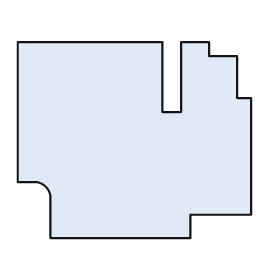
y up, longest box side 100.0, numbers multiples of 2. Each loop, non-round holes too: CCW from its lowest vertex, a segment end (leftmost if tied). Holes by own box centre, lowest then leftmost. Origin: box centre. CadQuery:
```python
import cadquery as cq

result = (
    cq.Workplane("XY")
    .moveTo(-36.0, -42.0)
    .lineTo(24.0, -42.0)
    .lineTo(24.0, -32.0)
    .lineTo(50.0, -32.0)
    .lineTo(50.0, 18.0)
    .lineTo(44.0, 18.0)
    .lineTo(44.0, 36.0)
    .lineTo(32.0, 36.0)
    .lineTo(32.0, 42.0)
    .lineTo(20.0, 42.0)
    .lineTo(20.0, 12.0)
    .lineTo(12.0, 12.0)
    .lineTo(12.0, 42.0)
    .lineTo(-50.0, 42.0)
    .lineTo(-50.0, -18.0)
    .lineTo(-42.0, -18.0)
    .threePointArc((-38.0, -20.0), (-36.0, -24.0))
    .close()
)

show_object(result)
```